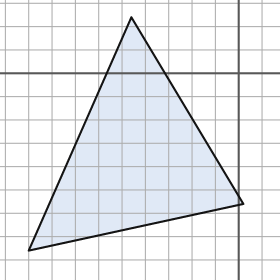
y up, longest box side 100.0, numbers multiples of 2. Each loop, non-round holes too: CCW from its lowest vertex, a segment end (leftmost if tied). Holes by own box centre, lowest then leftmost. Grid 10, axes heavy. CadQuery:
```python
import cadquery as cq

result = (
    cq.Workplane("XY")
    .moveTo(-90.0, -76.0)
    .lineTo(2.0, -56.0)
    .lineTo(-46.0, 24.0)
    .close()
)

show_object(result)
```